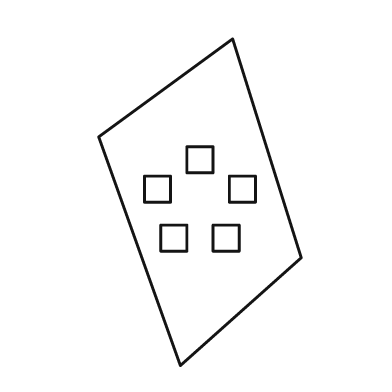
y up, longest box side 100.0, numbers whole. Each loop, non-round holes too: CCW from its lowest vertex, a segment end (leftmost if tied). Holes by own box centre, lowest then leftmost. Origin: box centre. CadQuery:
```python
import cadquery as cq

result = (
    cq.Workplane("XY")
    .moveTo(-6.0, -50.0)
    .lineTo(31.0, -17.0)
    .lineTo(10.0, 50.0)
    .lineTo(-31.0, 20.0)
    .close()
    .moveTo(-12.0, -15.0)
    .lineTo(-4.0, -15.0)
    .lineTo(-4.0, -7.0)
    .lineTo(-12.0, -7.0)
    .close()
    .moveTo(4.0, -15.0)
    .lineTo(12.0, -15.0)
    .lineTo(12.0, -7.0)
    .lineTo(4.0, -7.0)
    .close()
    .moveTo(-17.0, 0.0)
    .lineTo(-9.0, 0.0)
    .lineTo(-9.0, 8.0)
    .lineTo(-17.0, 8.0)
    .close()
    .moveTo(9.0, 0.0)
    .lineTo(17.0, 0.0)
    .lineTo(17.0, 8.0)
    .lineTo(9.0, 8.0)
    .close()
    .moveTo(-4.0, 9.0)
    .lineTo(4.0, 9.0)
    .lineTo(4.0, 17.0)
    .lineTo(-4.0, 17.0)
    .close()
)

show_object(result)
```